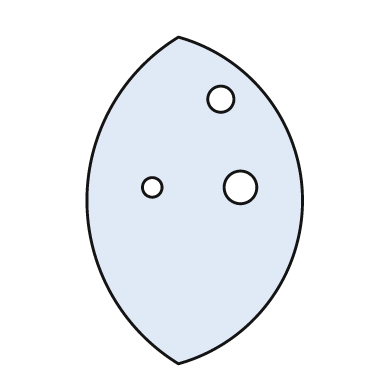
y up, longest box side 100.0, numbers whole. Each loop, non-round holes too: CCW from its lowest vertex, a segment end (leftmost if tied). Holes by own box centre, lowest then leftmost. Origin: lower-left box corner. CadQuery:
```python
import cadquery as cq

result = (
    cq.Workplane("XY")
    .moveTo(28.0, 0.0)
    .threePointArc((66.0, 50.0), (28.0, 100.0))
    .threePointArc((0.0, 50.0), (28.0, 0.0))
    .close()
    .moveTo(20.0, 54.0)
    .circle(3.0)
    .moveTo(47.0, 54.0)
    .circle(5.0)
    .moveTo(41.0, 81.0)
    .circle(4.0)
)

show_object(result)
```